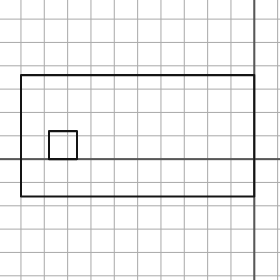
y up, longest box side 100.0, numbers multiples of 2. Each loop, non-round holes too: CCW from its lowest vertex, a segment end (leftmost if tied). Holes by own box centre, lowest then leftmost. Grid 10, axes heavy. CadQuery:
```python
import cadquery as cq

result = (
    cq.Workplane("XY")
    .moveTo(-100.0, -16.0)
    .lineTo(0.0, -16.0)
    .lineTo(0.0, 36.0)
    .lineTo(-100.0, 36.0)
    .close()
    .moveTo(-88.0, 0.0)
    .lineTo(-76.0, 0.0)
    .lineTo(-76.0, 12.0)
    .lineTo(-88.0, 12.0)
    .close()
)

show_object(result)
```